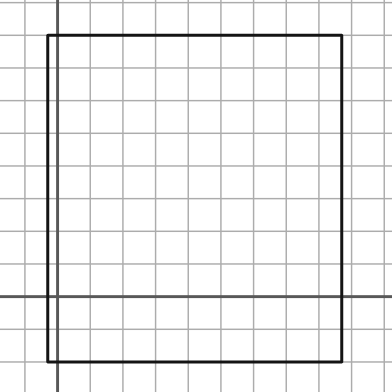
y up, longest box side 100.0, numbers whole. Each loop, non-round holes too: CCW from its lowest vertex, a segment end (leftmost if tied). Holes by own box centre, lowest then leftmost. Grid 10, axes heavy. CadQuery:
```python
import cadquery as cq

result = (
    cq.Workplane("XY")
    .moveTo(-3.0, -20.0)
    .lineTo(87.0, -20.0)
    .lineTo(87.0, 80.0)
    .lineTo(-3.0, 80.0)
    .close()
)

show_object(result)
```